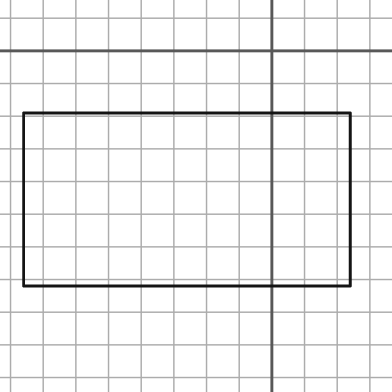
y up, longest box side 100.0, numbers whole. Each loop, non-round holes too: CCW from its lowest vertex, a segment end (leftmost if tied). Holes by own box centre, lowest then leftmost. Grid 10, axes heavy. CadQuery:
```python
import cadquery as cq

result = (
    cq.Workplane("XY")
    .moveTo(-76.0, -72.0)
    .lineTo(24.0, -72.0)
    .lineTo(24.0, -19.0)
    .lineTo(-76.0, -19.0)
    .close()
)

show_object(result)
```